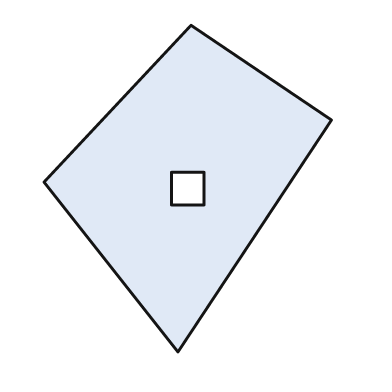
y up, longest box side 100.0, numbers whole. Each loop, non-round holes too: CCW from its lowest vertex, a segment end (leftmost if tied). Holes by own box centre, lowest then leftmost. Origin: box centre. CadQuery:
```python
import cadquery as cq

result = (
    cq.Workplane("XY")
    .moveTo(-3.0, -50.0)
    .lineTo(44.0, 21.0)
    .lineTo(1.0, 50.0)
    .lineTo(-44.0, 2.0)
    .close()
    .moveTo(-5.0, -5.0)
    .lineTo(5.0, -5.0)
    .lineTo(5.0, 5.0)
    .lineTo(-5.0, 5.0)
    .close()
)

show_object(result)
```